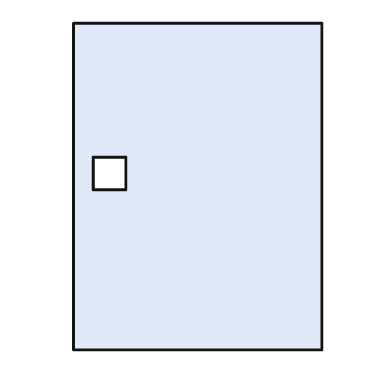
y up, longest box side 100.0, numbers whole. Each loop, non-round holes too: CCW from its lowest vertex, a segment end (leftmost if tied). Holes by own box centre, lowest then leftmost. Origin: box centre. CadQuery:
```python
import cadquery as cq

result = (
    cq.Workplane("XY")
    .moveTo(-38.0, -50.0)
    .lineTo(38.0, -50.0)
    .lineTo(38.0, 50.0)
    .lineTo(-38.0, 50.0)
    .close()
    .moveTo(-32.0, -1.0)
    .lineTo(-22.0, -1.0)
    .lineTo(-22.0, 9.0)
    .lineTo(-32.0, 9.0)
    .close()
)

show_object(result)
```